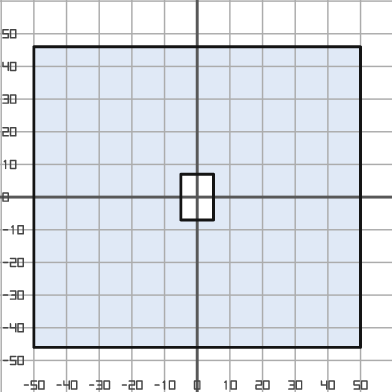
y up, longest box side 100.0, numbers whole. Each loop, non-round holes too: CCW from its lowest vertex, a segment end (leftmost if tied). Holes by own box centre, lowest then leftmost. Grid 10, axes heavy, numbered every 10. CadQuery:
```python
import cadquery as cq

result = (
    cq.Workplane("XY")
    .moveTo(-50.0, -46.0)
    .lineTo(50.0, -46.0)
    .lineTo(50.0, 46.0)
    .lineTo(-50.0, 46.0)
    .close()
    .moveTo(-5.0, -7.0)
    .lineTo(5.0, -7.0)
    .lineTo(5.0, 7.0)
    .lineTo(-5.0, 7.0)
    .close()
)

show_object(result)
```